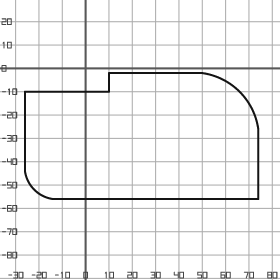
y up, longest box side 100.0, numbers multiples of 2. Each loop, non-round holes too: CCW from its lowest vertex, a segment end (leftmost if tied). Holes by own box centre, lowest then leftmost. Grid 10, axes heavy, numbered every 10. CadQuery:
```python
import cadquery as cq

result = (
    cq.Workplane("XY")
    .moveTo(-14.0, -56.0)
    .lineTo(74.0, -56.0)
    .lineTo(74.0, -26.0)
    .threePointArc((66.0, -10.0), (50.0, -2.0))
    .lineTo(10.0, -2.0)
    .lineTo(10.0, -10.0)
    .lineTo(-26.0, -10.0)
    .lineTo(-26.0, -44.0)
    .threePointArc((-22.0, -52.0), (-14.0, -56.0))
    .close()
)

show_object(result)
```